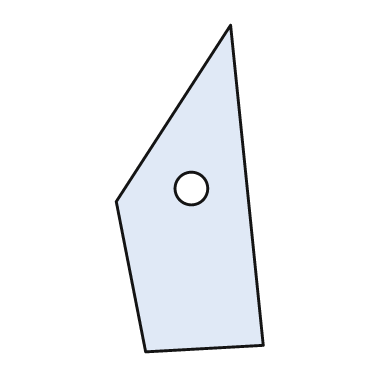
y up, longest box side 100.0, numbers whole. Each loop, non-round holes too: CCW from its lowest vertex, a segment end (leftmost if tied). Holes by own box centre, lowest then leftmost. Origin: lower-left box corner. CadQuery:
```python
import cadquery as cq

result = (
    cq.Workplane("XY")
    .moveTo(9.0, 0.0)
    .lineTo(45.0, 2.0)
    .lineTo(35.0, 100.0)
    .lineTo(0.0, 46.0)
    .close()
    .moveTo(23.0, 50.0)
    .circle(5.0)
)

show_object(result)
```